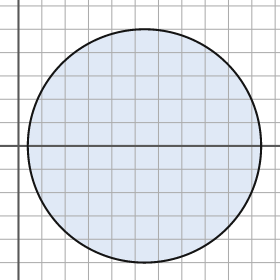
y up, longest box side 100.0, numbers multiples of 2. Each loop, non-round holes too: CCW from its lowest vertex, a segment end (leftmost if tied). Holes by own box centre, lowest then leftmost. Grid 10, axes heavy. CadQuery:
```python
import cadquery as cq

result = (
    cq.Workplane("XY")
    .moveTo(54.0, 0.0)
    .circle(50.0)
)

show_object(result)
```